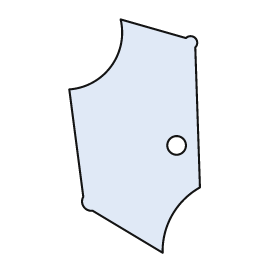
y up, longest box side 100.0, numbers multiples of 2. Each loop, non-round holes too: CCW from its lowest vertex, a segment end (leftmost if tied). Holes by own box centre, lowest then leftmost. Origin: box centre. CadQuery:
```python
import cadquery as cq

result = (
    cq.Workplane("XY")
    .moveTo(12.0, -50.0)
    .threePointArc((16.0, -34.0), (28.0, -22.0))
    .lineTo(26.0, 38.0)
    .threePointArc((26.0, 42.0), (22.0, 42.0))
    .lineTo(-6.0, 50.0)
    .threePointArc((-10.0, 30.0), (-28.0, 20.0))
    .lineTo(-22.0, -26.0)
    .threePointArc((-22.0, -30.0), (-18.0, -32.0))
    .close()
    .moveTo(18.0, -4.0)
    .circle(4.0)
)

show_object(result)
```